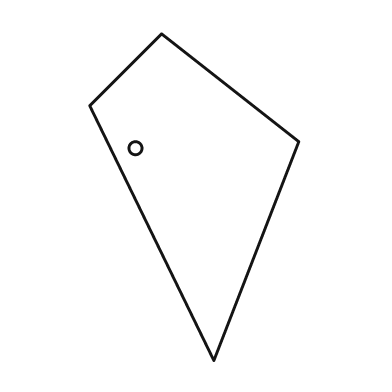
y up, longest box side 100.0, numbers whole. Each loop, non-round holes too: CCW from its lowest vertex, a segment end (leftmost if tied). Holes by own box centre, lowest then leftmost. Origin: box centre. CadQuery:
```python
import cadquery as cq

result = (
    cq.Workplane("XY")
    .moveTo(6.0, -50.0)
    .lineTo(32.0, 17.0)
    .lineTo(-10.0, 50.0)
    .lineTo(-32.0, 28.0)
    .close()
    .moveTo(-18.0, 15.0)
    .circle(2.0)
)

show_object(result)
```